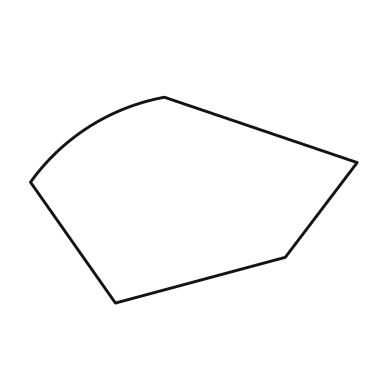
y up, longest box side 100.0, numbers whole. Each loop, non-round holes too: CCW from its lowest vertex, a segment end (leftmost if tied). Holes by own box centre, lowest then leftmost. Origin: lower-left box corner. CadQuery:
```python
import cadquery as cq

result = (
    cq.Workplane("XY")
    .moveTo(26.0, 0.0)
    .lineTo(78.0, 14.0)
    .lineTo(100.0, 43.0)
    .lineTo(41.0, 63.0)
    .threePointArc((18.0, 54.0), (0.0, 37.0))
    .close()
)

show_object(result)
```